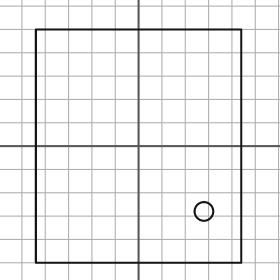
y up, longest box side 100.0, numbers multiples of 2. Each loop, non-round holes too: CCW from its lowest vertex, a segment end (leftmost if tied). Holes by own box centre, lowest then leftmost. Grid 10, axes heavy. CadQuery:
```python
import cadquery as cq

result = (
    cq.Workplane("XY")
    .moveTo(-44.0, -50.0)
    .lineTo(44.0, -50.0)
    .lineTo(44.0, 50.0)
    .lineTo(-44.0, 50.0)
    .close()
    .moveTo(28.0, -28.0)
    .circle(4.0)
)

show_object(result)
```